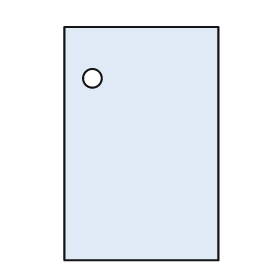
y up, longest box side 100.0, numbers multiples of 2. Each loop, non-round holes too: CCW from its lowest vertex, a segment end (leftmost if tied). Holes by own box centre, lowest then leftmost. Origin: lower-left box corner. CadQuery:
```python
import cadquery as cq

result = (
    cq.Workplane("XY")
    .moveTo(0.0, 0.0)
    .lineTo(66.0, 0.0)
    .lineTo(66.0, 100.0)
    .lineTo(0.0, 100.0)
    .close()
    .moveTo(12.0, 78.0)
    .circle(4.0)
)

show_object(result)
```